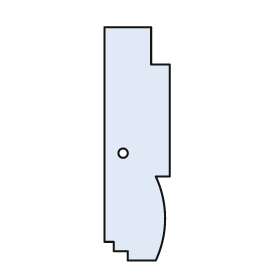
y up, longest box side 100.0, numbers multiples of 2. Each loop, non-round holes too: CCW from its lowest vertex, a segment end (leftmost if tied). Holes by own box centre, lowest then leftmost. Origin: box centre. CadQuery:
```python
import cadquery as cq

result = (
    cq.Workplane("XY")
    .moveTo(-4.0, -50.0)
    .lineTo(8.0, -50.0)
    .threePointArc((12.0, -32.0), (8.0, -14.0))
    .lineTo(14.0, -14.0)
    .lineTo(14.0, 34.0)
    .lineTo(6.0, 34.0)
    .lineTo(6.0, 50.0)
    .lineTo(-14.0, 50.0)
    .lineTo(-14.0, -42.0)
    .lineTo(-10.0, -42.0)
    .lineTo(-10.0, -46.0)
    .lineTo(-4.0, -46.0)
    .close()
    .moveTo(-6.0, -4.0)
    .circle(2.0)
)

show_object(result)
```